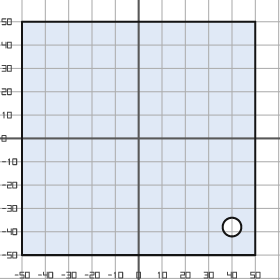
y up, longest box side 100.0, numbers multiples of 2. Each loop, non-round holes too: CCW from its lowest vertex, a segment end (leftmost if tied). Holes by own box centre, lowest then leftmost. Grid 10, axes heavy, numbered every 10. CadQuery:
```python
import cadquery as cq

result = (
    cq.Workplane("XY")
    .moveTo(-50.0, -50.0)
    .lineTo(50.0, -50.0)
    .lineTo(50.0, 50.0)
    .lineTo(-50.0, 50.0)
    .close()
    .moveTo(40.0, -38.0)
    .circle(4.0)
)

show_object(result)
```